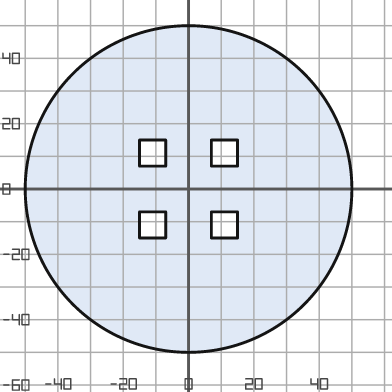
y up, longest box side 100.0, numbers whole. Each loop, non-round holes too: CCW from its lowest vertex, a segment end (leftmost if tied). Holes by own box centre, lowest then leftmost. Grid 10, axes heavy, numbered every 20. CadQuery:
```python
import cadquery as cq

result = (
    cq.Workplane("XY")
    .moveTo(0.0, 0.0)
    .circle(50.0)
    .moveTo(-15.0, -15.0)
    .lineTo(-7.0, -15.0)
    .lineTo(-7.0, -7.0)
    .lineTo(-15.0, -7.0)
    .close()
    .moveTo(7.0, -15.0)
    .lineTo(15.0, -15.0)
    .lineTo(15.0, -7.0)
    .lineTo(7.0, -7.0)
    .close()
    .moveTo(-15.0, 7.0)
    .lineTo(-7.0, 7.0)
    .lineTo(-7.0, 15.0)
    .lineTo(-15.0, 15.0)
    .close()
    .moveTo(7.0, 7.0)
    .lineTo(15.0, 7.0)
    .lineTo(15.0, 15.0)
    .lineTo(7.0, 15.0)
    .close()
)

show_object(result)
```